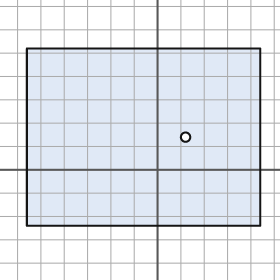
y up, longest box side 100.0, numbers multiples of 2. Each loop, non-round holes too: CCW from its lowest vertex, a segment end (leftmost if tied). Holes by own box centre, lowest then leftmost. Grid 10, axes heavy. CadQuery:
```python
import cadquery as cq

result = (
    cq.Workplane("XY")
    .moveTo(-56.0, -24.0)
    .lineTo(44.0, -24.0)
    .lineTo(44.0, 52.0)
    .lineTo(-56.0, 52.0)
    .close()
    .moveTo(12.0, 14.0)
    .circle(2.0)
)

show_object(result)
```